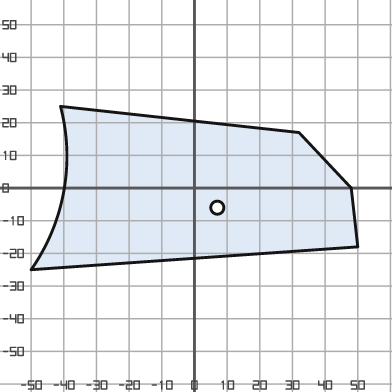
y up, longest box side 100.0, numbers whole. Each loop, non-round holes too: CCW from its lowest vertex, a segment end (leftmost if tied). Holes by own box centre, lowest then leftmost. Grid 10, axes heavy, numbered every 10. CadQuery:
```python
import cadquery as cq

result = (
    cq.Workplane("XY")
    .moveTo(-50.0, -25.0)
    .lineTo(50.0, -18.0)
    .lineTo(48.0, 0.0)
    .lineTo(32.0, 17.0)
    .lineTo(-41.0, 25.0)
    .threePointArc((-40.0, -1.0), (-50.0, -25.0))
    .close()
    .moveTo(7.0, -6.0)
    .circle(2.0)
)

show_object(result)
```